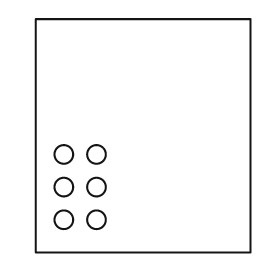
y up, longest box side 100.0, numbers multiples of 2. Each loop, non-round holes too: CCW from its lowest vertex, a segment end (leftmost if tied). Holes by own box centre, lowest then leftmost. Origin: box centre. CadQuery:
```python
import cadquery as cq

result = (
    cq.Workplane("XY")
    .moveTo(-46.0, -50.0)
    .lineTo(46.0, -50.0)
    .lineTo(46.0, 50.0)
    .lineTo(-46.0, 50.0)
    .close()
    .moveTo(-34.0, -36.0)
    .circle(4.0)
    .moveTo(-20.0, -36.0)
    .circle(4.0)
    .moveTo(-34.0, -22.0)
    .circle(4.0)
    .moveTo(-20.0, -22.0)
    .circle(4.0)
    .moveTo(-34.0, -8.0)
    .circle(4.0)
    .moveTo(-20.0, -8.0)
    .circle(4.0)
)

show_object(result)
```